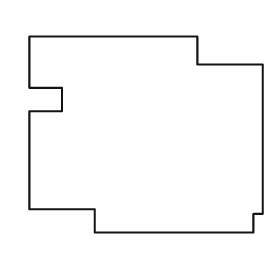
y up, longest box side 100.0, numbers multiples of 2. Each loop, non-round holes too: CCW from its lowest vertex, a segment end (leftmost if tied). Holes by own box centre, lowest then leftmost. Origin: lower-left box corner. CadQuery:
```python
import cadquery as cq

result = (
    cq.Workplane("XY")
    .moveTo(28.0, 0.0)
    .lineTo(96.0, 0.0)
    .lineTo(96.0, 8.0)
    .lineTo(100.0, 8.0)
    .lineTo(100.0, 72.0)
    .lineTo(72.0, 72.0)
    .lineTo(72.0, 84.0)
    .lineTo(0.0, 84.0)
    .lineTo(0.0, 62.0)
    .lineTo(14.0, 62.0)
    .lineTo(14.0, 52.0)
    .lineTo(0.0, 52.0)
    .lineTo(0.0, 10.0)
    .lineTo(28.0, 10.0)
    .close()
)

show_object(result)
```